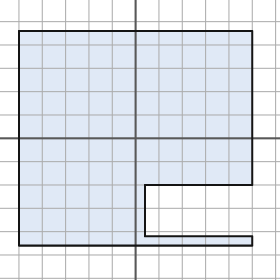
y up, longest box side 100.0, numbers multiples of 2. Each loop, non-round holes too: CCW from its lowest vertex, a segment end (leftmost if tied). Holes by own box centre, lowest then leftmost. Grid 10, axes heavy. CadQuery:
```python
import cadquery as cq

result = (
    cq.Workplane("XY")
    .moveTo(-50.0, -46.0)
    .lineTo(50.0, -46.0)
    .lineTo(50.0, -42.0)
    .lineTo(4.0, -42.0)
    .lineTo(4.0, -20.0)
    .lineTo(50.0, -20.0)
    .lineTo(50.0, 46.0)
    .lineTo(-50.0, 46.0)
    .close()
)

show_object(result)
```